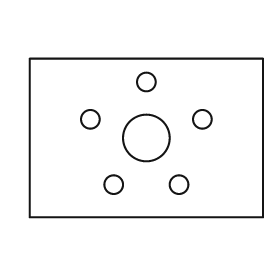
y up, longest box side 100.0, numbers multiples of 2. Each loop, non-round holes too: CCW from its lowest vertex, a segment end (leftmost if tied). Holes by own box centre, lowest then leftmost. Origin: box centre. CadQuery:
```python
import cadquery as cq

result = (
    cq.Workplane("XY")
    .moveTo(-50.0, -34.0)
    .lineTo(50.0, -34.0)
    .lineTo(50.0, 34.0)
    .lineTo(-50.0, 34.0)
    .close()
    .moveTo(-14.0, -20.0)
    .circle(4.0)
    .moveTo(14.0, -20.0)
    .circle(4.0)
    .moveTo(0.0, 0.0)
    .circle(10.0)
    .moveTo(-24.0, 8.0)
    .circle(4.0)
    .moveTo(24.0, 8.0)
    .circle(4.0)
    .moveTo(0.0, 24.0)
    .circle(4.0)
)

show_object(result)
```